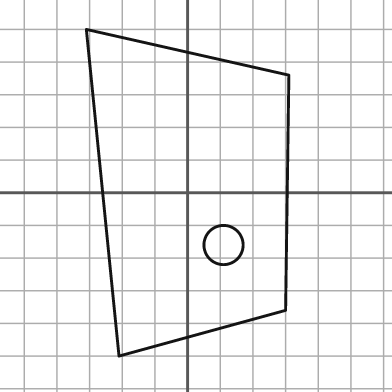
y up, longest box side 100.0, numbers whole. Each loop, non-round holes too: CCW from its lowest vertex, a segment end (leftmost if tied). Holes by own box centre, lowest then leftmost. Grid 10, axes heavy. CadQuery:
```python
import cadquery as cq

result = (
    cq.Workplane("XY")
    .moveTo(-21.0, -50.0)
    .lineTo(30.0, -36.0)
    .lineTo(31.0, 36.0)
    .lineTo(-31.0, 50.0)
    .close()
    .moveTo(11.0, -16.0)
    .circle(6.0)
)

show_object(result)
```